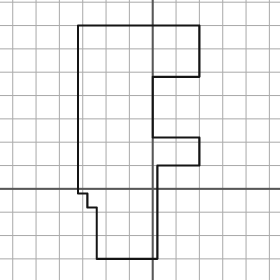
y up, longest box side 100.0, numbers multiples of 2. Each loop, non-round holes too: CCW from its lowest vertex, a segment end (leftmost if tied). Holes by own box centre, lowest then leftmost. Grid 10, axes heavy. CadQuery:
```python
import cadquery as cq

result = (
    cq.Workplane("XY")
    .moveTo(-24.0, -30.0)
    .lineTo(2.0, -30.0)
    .lineTo(2.0, 10.0)
    .lineTo(20.0, 10.0)
    .lineTo(20.0, 22.0)
    .lineTo(0.0, 22.0)
    .lineTo(0.0, 48.0)
    .lineTo(20.0, 48.0)
    .lineTo(20.0, 70.0)
    .lineTo(-32.0, 70.0)
    .lineTo(-32.0, -2.0)
    .lineTo(-28.0, -2.0)
    .lineTo(-28.0, -8.0)
    .lineTo(-24.0, -8.0)
    .close()
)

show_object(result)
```